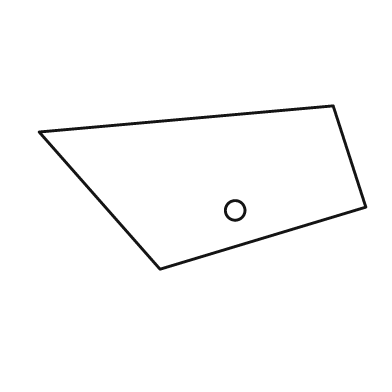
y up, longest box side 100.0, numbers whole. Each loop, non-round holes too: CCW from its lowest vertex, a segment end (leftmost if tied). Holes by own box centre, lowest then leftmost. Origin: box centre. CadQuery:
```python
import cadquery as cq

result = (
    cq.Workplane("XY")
    .moveTo(-13.0, -25.0)
    .lineTo(50.0, -6.0)
    .lineTo(40.0, 25.0)
    .lineTo(-50.0, 17.0)
    .close()
    .moveTo(10.0, -7.0)
    .circle(3.0)
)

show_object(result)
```